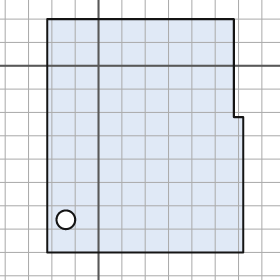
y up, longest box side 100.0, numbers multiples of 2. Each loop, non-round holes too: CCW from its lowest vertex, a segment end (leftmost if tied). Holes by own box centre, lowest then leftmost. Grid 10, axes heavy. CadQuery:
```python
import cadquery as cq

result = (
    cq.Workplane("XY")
    .moveTo(-22.0, -80.0)
    .lineTo(62.0, -80.0)
    .lineTo(62.0, -22.0)
    .lineTo(58.0, -22.0)
    .lineTo(58.0, 20.0)
    .lineTo(-22.0, 20.0)
    .close()
    .moveTo(-14.0, -66.0)
    .circle(4.0)
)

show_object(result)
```